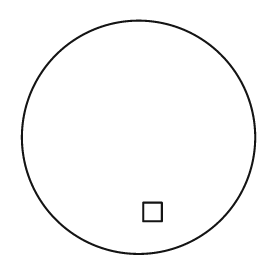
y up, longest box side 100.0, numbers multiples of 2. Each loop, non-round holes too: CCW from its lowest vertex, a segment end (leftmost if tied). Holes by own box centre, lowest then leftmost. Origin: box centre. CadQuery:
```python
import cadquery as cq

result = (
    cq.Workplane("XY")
    .moveTo(0.0, 0.0)
    .circle(50.0)
    .moveTo(2.0, -36.0)
    .lineTo(10.0, -36.0)
    .lineTo(10.0, -28.0)
    .lineTo(2.0, -28.0)
    .close()
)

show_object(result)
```